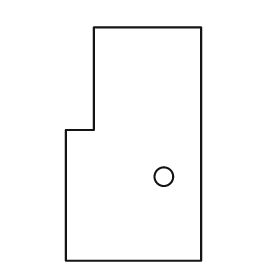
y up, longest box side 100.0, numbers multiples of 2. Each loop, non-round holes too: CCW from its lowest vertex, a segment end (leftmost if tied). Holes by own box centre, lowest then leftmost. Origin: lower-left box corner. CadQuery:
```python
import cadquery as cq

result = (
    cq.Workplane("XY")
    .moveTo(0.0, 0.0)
    .lineTo(58.0, 0.0)
    .lineTo(58.0, 100.0)
    .lineTo(12.0, 100.0)
    .lineTo(12.0, 56.0)
    .lineTo(0.0, 56.0)
    .close()
    .moveTo(42.0, 36.0)
    .circle(4.0)
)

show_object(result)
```